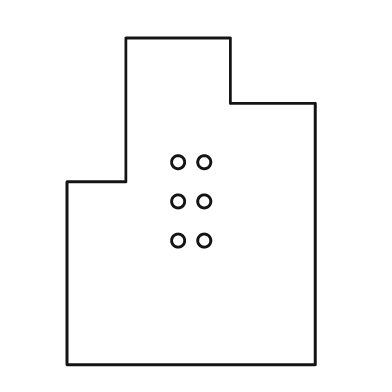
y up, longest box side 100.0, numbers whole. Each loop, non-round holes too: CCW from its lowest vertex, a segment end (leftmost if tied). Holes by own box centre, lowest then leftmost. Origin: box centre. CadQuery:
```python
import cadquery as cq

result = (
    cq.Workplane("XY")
    .moveTo(-38.0, -50.0)
    .lineTo(38.0, -50.0)
    .lineTo(38.0, 30.0)
    .lineTo(12.0, 30.0)
    .lineTo(12.0, 50.0)
    .lineTo(-20.0, 50.0)
    .lineTo(-20.0, 6.0)
    .lineTo(-38.0, 6.0)
    .close()
    .moveTo(-4.0, -12.0)
    .circle(2.0)
    .moveTo(4.0, -12.0)
    .circle(2.0)
    .moveTo(-4.0, 0.0)
    .circle(2.0)
    .moveTo(4.0, 0.0)
    .circle(2.0)
    .moveTo(-4.0, 12.0)
    .circle(2.0)
    .moveTo(4.0, 12.0)
    .circle(2.0)
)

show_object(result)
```